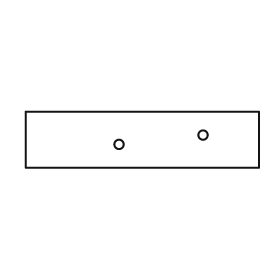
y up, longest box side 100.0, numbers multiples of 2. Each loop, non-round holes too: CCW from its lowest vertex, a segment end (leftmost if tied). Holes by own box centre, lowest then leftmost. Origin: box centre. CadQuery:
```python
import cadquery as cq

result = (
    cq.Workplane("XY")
    .moveTo(-50.0, -12.0)
    .lineTo(50.0, -12.0)
    .lineTo(50.0, 12.0)
    .lineTo(-50.0, 12.0)
    .close()
    .moveTo(-10.0, -2.0)
    .circle(2.0)
    .moveTo(26.0, 2.0)
    .circle(2.0)
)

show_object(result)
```